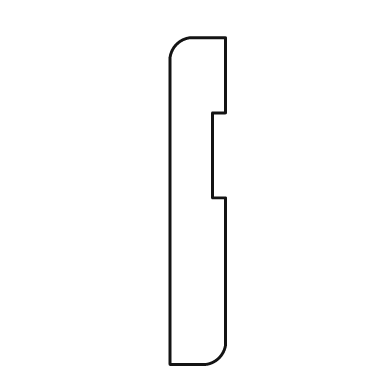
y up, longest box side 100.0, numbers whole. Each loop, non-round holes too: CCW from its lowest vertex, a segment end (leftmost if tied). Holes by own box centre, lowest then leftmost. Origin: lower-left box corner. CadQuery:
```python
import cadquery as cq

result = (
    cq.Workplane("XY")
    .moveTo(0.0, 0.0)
    .lineTo(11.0, 0.0)
    .threePointArc((15.0, 2.0), (17.0, 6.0))
    .lineTo(17.0, 51.0)
    .lineTo(13.0, 51.0)
    .lineTo(13.0, 77.0)
    .lineTo(17.0, 77.0)
    .lineTo(17.0, 100.0)
    .lineTo(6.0, 100.0)
    .threePointArc((2.0, 98.0), (0.0, 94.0))
    .close()
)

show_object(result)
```